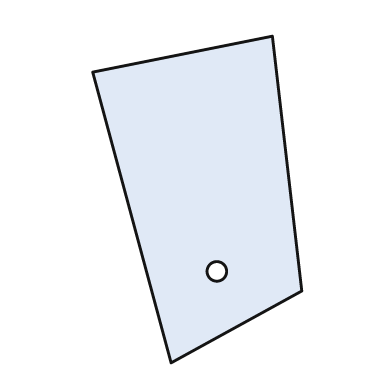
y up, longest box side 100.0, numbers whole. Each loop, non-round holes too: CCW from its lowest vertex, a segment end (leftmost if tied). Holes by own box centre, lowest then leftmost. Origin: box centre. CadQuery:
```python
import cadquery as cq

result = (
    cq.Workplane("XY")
    .moveTo(-8.0, -50.0)
    .lineTo(32.0, -28.0)
    .lineTo(23.0, 50.0)
    .lineTo(-32.0, 39.0)
    .close()
    .moveTo(6.0, -22.0)
    .circle(3.0)
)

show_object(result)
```